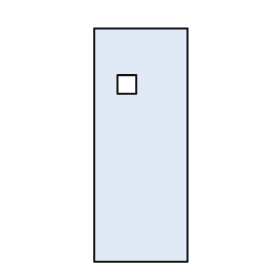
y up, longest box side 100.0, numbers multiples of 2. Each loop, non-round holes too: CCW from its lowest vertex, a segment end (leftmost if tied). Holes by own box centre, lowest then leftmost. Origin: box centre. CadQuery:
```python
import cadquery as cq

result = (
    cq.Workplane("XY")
    .moveTo(-20.0, -50.0)
    .lineTo(20.0, -50.0)
    .lineTo(20.0, 50.0)
    .lineTo(-20.0, 50.0)
    .close()
    .moveTo(-10.0, 22.0)
    .lineTo(-2.0, 22.0)
    .lineTo(-2.0, 30.0)
    .lineTo(-10.0, 30.0)
    .close()
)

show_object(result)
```